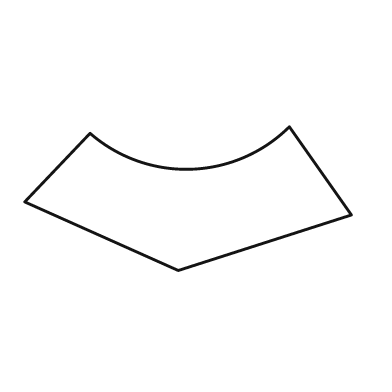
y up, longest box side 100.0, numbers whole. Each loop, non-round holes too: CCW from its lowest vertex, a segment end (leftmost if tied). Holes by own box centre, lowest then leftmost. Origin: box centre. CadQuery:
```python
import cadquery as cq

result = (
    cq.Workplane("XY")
    .moveTo(-3.0, -22.0)
    .lineTo(50.0, -5.0)
    .lineTo(31.0, 22.0)
    .threePointArc((1.0, 9.0), (-30.0, 20.0))
    .lineTo(-50.0, -1.0)
    .close()
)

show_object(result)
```